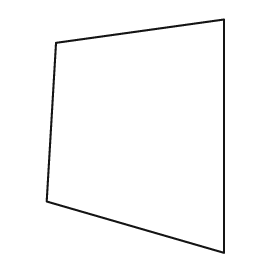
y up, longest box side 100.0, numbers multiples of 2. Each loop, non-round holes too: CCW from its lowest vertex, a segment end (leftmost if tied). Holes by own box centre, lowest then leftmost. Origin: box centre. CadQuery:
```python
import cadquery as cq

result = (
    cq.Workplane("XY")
    .moveTo(38.0, -50.0)
    .lineTo(38.0, 50.0)
    .lineTo(-34.0, 40.0)
    .lineTo(-38.0, -28.0)
    .close()
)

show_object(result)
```